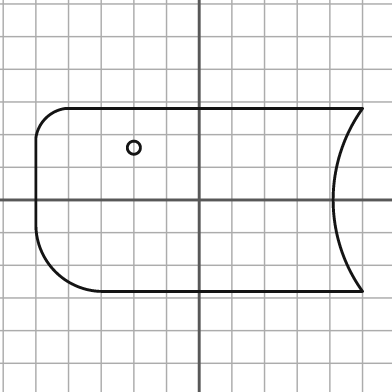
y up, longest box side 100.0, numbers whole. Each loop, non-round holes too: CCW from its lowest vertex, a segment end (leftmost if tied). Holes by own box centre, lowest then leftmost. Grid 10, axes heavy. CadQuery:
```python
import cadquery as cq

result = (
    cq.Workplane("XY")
    .moveTo(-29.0, -28.0)
    .lineTo(50.0, -28.0)
    .threePointArc((41.0, 0.0), (50.0, 28.0))
    .lineTo(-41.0, 28.0)
    .threePointArc((-47.0, 25.0), (-50.0, 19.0))
    .lineTo(-50.0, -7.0)
    .threePointArc((-44.0, -22.0), (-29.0, -28.0))
    .close()
    .moveTo(-20.0, 16.0)
    .circle(2.0)
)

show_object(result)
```